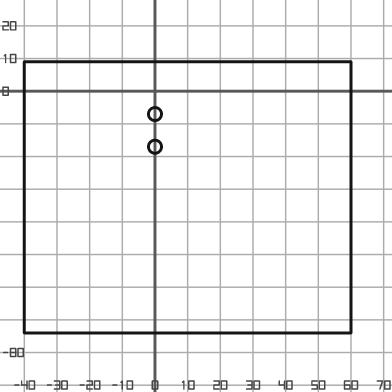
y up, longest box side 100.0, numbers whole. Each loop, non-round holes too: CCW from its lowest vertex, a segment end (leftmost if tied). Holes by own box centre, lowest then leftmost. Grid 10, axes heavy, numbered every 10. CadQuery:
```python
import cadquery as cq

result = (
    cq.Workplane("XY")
    .moveTo(-40.0, -74.0)
    .lineTo(60.0, -74.0)
    .lineTo(60.0, 9.0)
    .lineTo(-40.0, 9.0)
    .close()
    .moveTo(0.0, -17.0)
    .circle(2.0)
    .moveTo(0.0, -7.0)
    .circle(2.0)
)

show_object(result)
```